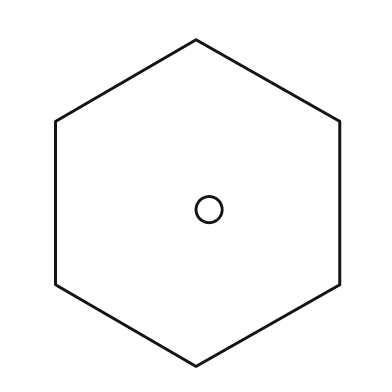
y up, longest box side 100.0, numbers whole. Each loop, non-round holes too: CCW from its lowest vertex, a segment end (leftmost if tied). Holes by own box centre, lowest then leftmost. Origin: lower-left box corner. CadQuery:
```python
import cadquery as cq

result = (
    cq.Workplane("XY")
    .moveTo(43.0, 0.0)
    .lineTo(87.0, 25.0)
    .lineTo(87.0, 75.0)
    .lineTo(43.0, 100.0)
    .lineTo(0.0, 75.0)
    .lineTo(0.0, 25.0)
    .close()
    .moveTo(47.0, 48.0)
    .circle(4.0)
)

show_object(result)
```